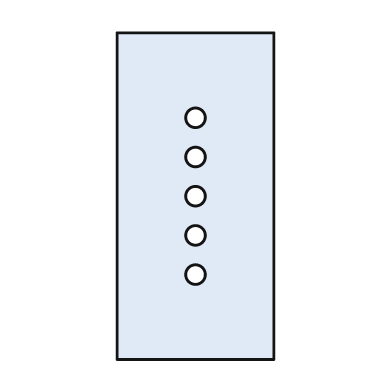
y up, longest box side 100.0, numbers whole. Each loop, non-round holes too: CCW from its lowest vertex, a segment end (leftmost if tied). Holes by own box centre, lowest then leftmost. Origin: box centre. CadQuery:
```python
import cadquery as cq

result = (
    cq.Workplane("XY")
    .moveTo(-24.0, -50.0)
    .lineTo(24.0, -50.0)
    .lineTo(24.0, 50.0)
    .lineTo(-24.0, 50.0)
    .close()
    .moveTo(0.0, -24.0)
    .circle(3.0)
    .moveTo(0.0, -12.0)
    .circle(3.0)
    .moveTo(0.0, 0.0)
    .circle(3.0)
    .moveTo(0.0, 12.0)
    .circle(3.0)
    .moveTo(0.0, 24.0)
    .circle(3.0)
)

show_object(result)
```